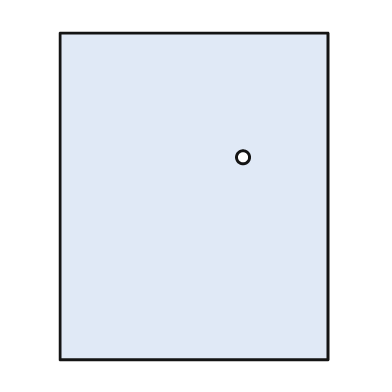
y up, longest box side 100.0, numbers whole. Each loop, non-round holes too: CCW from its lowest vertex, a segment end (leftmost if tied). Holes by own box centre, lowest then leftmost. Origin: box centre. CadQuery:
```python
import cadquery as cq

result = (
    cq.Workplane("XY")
    .moveTo(-41.0, -50.0)
    .lineTo(41.0, -50.0)
    .lineTo(41.0, 50.0)
    .lineTo(-41.0, 50.0)
    .close()
    .moveTo(15.0, 12.0)
    .circle(2.0)
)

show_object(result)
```